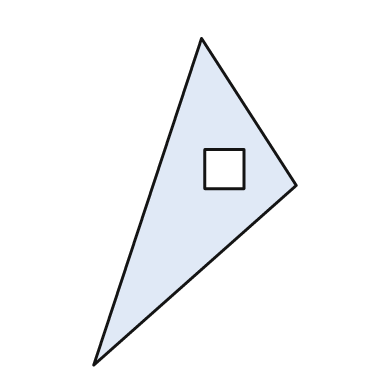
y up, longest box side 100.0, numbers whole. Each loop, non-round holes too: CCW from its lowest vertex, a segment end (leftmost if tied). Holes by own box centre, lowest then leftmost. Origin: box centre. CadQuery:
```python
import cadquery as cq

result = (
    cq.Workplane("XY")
    .moveTo(-31.0, -50.0)
    .lineTo(31.0, 5.0)
    .lineTo(2.0, 50.0)
    .close()
    .moveTo(3.0, 4.0)
    .lineTo(15.0, 4.0)
    .lineTo(15.0, 16.0)
    .lineTo(3.0, 16.0)
    .close()
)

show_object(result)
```